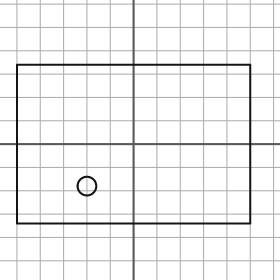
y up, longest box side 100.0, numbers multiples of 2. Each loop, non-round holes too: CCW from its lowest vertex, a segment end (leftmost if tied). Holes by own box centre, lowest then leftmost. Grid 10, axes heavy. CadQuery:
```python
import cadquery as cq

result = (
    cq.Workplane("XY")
    .moveTo(-50.0, -34.0)
    .lineTo(50.0, -34.0)
    .lineTo(50.0, 34.0)
    .lineTo(-50.0, 34.0)
    .close()
    .moveTo(-20.0, -18.0)
    .circle(4.0)
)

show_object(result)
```